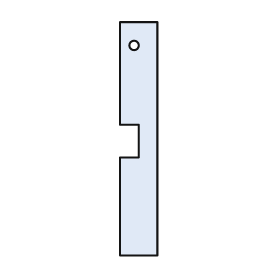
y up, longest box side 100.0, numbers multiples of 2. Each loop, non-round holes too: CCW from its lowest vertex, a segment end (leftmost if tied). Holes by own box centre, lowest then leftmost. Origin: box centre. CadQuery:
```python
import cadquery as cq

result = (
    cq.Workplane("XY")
    .moveTo(-8.0, -50.0)
    .lineTo(8.0, -50.0)
    .lineTo(8.0, 50.0)
    .lineTo(-8.0, 50.0)
    .lineTo(-8.0, 6.0)
    .lineTo(0.0, 6.0)
    .lineTo(0.0, -8.0)
    .lineTo(-8.0, -8.0)
    .close()
    .moveTo(-2.0, 40.0)
    .circle(2.0)
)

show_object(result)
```